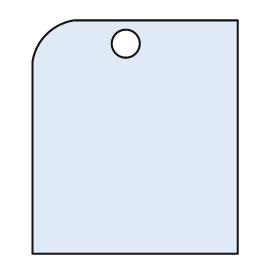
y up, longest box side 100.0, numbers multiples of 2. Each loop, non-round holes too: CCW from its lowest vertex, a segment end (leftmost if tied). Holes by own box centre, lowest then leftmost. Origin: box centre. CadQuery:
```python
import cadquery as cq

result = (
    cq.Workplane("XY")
    .moveTo(-44.0, -50.0)
    .lineTo(44.0, -50.0)
    .lineTo(44.0, 50.0)
    .lineTo(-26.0, 50.0)
    .threePointArc((-38.0, 44.0), (-44.0, 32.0))
    .close()
    .moveTo(-4.0, 40.0)
    .circle(6.0)
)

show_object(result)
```